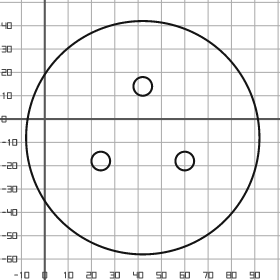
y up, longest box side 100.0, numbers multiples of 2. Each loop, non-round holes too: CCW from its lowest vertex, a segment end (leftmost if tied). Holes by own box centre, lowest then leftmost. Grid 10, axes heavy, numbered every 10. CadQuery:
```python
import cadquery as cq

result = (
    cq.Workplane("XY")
    .moveTo(42.0, -8.0)
    .circle(50.0)
    .moveTo(24.0, -18.0)
    .circle(4.0)
    .moveTo(60.0, -18.0)
    .circle(4.0)
    .moveTo(42.0, 14.0)
    .circle(4.0)
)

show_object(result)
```